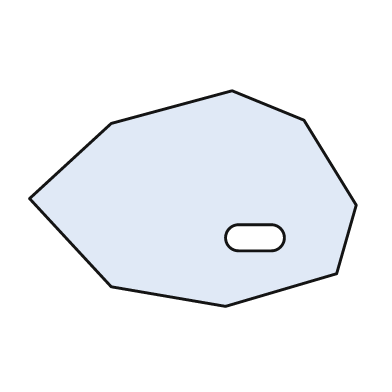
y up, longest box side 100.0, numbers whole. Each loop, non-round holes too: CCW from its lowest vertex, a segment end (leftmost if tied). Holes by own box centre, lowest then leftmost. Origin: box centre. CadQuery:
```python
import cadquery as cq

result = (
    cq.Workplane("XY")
    .moveTo(10.0, -33.0)
    .lineTo(44.0, -23.0)
    .lineTo(50.0, -2.0)
    .lineTo(34.0, 24.0)
    .lineTo(12.0, 33.0)
    .lineTo(-25.0, 23.0)
    .lineTo(-50.0, 0.0)
    .lineTo(-25.0, -27.0)
    .close()
    .moveTo(14.0, -16.0)
    .lineTo(24.0, -16.0)
    .threePointArc((28.0, -12.0), (24.0, -8.0))
    .lineTo(14.0, -8.0)
    .threePointArc((10.0, -12.0), (14.0, -16.0))
    .close()
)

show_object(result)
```